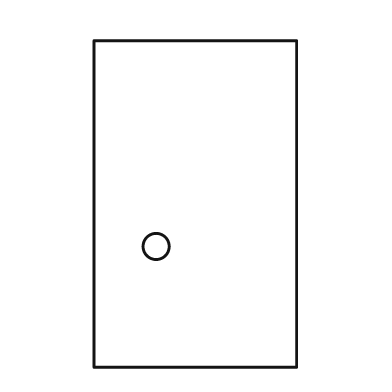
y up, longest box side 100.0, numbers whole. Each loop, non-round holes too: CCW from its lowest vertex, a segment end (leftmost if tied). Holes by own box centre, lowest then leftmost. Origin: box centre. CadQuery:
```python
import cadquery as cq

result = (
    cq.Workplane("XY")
    .moveTo(-31.0, -50.0)
    .lineTo(31.0, -50.0)
    .lineTo(31.0, 50.0)
    .lineTo(-31.0, 50.0)
    .close()
    .moveTo(-12.0, -13.0)
    .circle(4.0)
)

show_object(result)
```